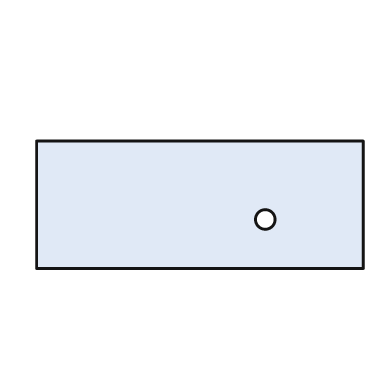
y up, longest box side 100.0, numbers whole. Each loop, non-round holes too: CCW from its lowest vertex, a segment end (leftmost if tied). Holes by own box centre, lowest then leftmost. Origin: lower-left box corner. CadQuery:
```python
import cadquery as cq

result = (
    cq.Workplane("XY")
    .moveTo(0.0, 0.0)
    .lineTo(100.0, 0.0)
    .lineTo(100.0, 39.0)
    .lineTo(0.0, 39.0)
    .close()
    .moveTo(70.0, 15.0)
    .circle(3.0)
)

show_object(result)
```